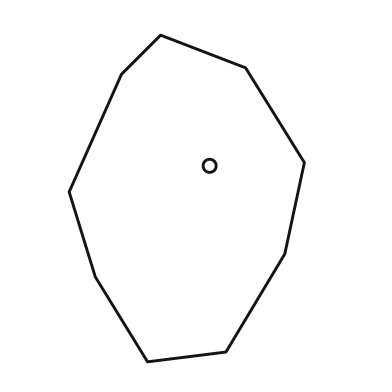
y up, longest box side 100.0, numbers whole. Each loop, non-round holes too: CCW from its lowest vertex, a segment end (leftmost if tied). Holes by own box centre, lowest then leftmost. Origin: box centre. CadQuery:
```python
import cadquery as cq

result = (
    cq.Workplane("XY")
    .moveTo(-12.0, -50.0)
    .lineTo(12.0, -47.0)
    .lineTo(30.0, -17.0)
    .lineTo(36.0, 11.0)
    .lineTo(18.0, 40.0)
    .lineTo(-8.0, 50.0)
    .lineTo(-20.0, 38.0)
    .lineTo(-36.0, 2.0)
    .lineTo(-28.0, -24.0)
    .close()
    .moveTo(7.0, 10.0)
    .circle(2.0)
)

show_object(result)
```